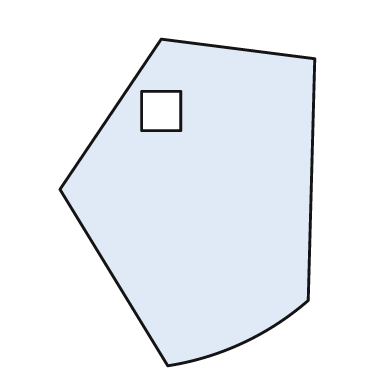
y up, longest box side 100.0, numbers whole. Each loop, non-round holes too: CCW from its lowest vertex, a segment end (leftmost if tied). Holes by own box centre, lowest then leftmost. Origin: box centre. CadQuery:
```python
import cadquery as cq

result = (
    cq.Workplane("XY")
    .moveTo(-6.0, -50.0)
    .threePointArc((17.0, -43.0), (37.0, -30.0))
    .lineTo(39.0, 44.0)
    .lineTo(-8.0, 50.0)
    .lineTo(-39.0, 4.0)
    .close()
    .moveTo(-14.0, 22.0)
    .lineTo(-2.0, 22.0)
    .lineTo(-2.0, 34.0)
    .lineTo(-14.0, 34.0)
    .close()
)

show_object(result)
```